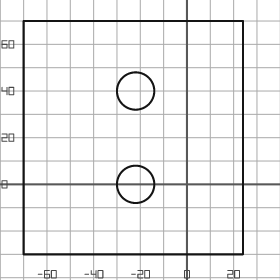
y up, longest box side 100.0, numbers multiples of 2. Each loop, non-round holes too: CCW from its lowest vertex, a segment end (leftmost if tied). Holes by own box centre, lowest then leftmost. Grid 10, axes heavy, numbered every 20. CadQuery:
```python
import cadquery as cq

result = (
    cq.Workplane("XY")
    .moveTo(-70.0, -30.0)
    .lineTo(24.0, -30.0)
    .lineTo(24.0, 70.0)
    .lineTo(-70.0, 70.0)
    .close()
    .moveTo(-22.0, 0.0)
    .circle(8.0)
    .moveTo(-22.0, 40.0)
    .circle(8.0)
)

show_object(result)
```